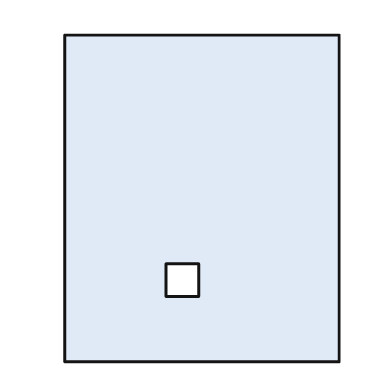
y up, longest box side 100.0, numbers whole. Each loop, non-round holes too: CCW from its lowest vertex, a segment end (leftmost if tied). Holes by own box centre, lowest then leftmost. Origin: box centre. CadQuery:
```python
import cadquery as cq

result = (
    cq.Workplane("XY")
    .moveTo(-42.0, -50.0)
    .lineTo(42.0, -50.0)
    .lineTo(42.0, 50.0)
    .lineTo(-42.0, 50.0)
    .close()
    .moveTo(-11.0, -30.0)
    .lineTo(-1.0, -30.0)
    .lineTo(-1.0, -20.0)
    .lineTo(-11.0, -20.0)
    .close()
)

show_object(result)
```